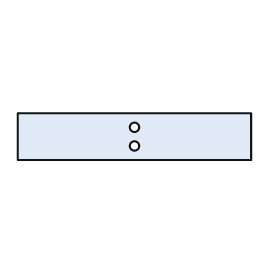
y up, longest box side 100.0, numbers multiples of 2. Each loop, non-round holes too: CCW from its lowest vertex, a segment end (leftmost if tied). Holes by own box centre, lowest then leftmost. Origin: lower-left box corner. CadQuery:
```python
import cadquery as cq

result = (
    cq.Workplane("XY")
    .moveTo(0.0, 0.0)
    .lineTo(100.0, 0.0)
    .lineTo(100.0, 20.0)
    .lineTo(0.0, 20.0)
    .close()
    .moveTo(50.0, 6.0)
    .circle(2.0)
    .moveTo(50.0, 14.0)
    .circle(2.0)
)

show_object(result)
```